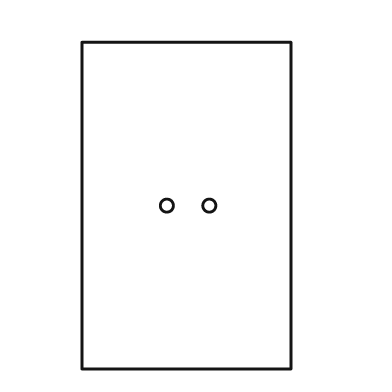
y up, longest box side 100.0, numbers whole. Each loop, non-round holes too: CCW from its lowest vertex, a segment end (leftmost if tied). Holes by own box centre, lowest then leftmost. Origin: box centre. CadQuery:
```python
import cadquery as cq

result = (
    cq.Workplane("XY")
    .moveTo(-32.0, -50.0)
    .lineTo(32.0, -50.0)
    .lineTo(32.0, 50.0)
    .lineTo(-32.0, 50.0)
    .close()
    .moveTo(-6.0, 0.0)
    .circle(2.0)
    .moveTo(7.0, 0.0)
    .circle(2.0)
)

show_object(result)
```